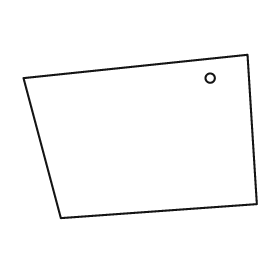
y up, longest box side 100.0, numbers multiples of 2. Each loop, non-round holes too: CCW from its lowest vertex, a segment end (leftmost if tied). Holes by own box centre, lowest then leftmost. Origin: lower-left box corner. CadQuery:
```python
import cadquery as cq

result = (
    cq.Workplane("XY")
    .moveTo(16.0, 0.0)
    .lineTo(100.0, 6.0)
    .lineTo(96.0, 70.0)
    .lineTo(0.0, 60.0)
    .close()
    .moveTo(80.0, 60.0)
    .circle(2.0)
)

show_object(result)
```